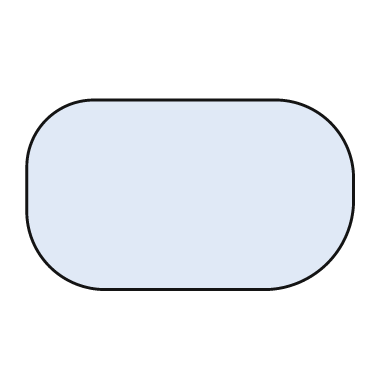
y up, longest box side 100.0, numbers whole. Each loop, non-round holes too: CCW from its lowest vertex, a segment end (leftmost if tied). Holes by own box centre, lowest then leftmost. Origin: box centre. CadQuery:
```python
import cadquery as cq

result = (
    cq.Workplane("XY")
    .moveTo(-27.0, -29.0)
    .lineTo(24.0, -29.0)
    .threePointArc((42.0, -21.0), (50.0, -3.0))
    .lineTo(50.0, 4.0)
    .threePointArc((43.0, 22.0), (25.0, 29.0))
    .lineTo(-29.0, 29.0)
    .threePointArc((-44.0, 23.0), (-50.0, 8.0))
    .lineTo(-50.0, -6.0)
    .threePointArc((-43.0, -22.0), (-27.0, -29.0))
    .close()
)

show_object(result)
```